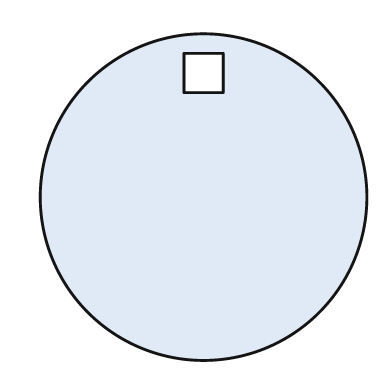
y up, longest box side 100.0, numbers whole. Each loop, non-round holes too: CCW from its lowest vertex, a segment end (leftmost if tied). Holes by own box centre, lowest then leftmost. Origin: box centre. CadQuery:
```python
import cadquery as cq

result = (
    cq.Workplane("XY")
    .moveTo(0.0, 0.0)
    .circle(50.0)
    .moveTo(-6.0, 32.0)
    .lineTo(6.0, 32.0)
    .lineTo(6.0, 44.0)
    .lineTo(-6.0, 44.0)
    .close()
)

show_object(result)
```